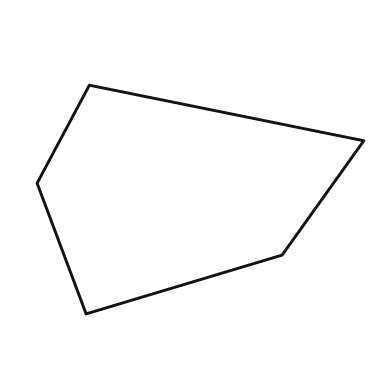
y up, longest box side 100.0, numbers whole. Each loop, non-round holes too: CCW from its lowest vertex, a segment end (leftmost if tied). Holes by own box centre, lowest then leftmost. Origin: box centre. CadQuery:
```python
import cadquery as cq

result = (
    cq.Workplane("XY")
    .moveTo(-35.0, -35.0)
    .lineTo(25.0, -17.0)
    .lineTo(50.0, 18.0)
    .lineTo(-34.0, 35.0)
    .lineTo(-50.0, 5.0)
    .close()
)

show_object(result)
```